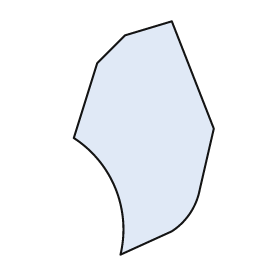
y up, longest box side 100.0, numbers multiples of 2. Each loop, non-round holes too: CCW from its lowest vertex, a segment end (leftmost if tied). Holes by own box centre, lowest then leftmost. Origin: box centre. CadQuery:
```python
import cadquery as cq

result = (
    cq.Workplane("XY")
    .moveTo(-10.0, -50.0)
    .lineTo(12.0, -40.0)
    .threePointArc((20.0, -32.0), (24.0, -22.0))
    .lineTo(30.0, 4.0)
    .lineTo(12.0, 50.0)
    .lineTo(-8.0, 44.0)
    .lineTo(-20.0, 32.0)
    .lineTo(-30.0, 0.0)
    .threePointArc((-12.0, -22.0), (-10.0, -50.0))
    .close()
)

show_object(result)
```